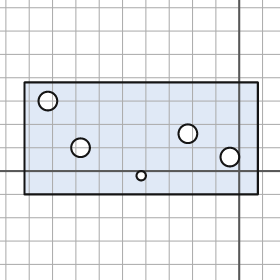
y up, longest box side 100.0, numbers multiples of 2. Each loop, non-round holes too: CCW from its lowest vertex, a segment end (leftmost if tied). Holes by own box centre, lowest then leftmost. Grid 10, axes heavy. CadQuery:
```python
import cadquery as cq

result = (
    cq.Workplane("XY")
    .moveTo(-92.0, -10.0)
    .lineTo(8.0, -10.0)
    .lineTo(8.0, 38.0)
    .lineTo(-92.0, 38.0)
    .close()
    .moveTo(-42.0, -2.0)
    .circle(2.0)
    .moveTo(-4.0, 6.0)
    .circle(4.0)
    .moveTo(-68.0, 10.0)
    .circle(4.0)
    .moveTo(-22.0, 16.0)
    .circle(4.0)
    .moveTo(-82.0, 30.0)
    .circle(4.0)
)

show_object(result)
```